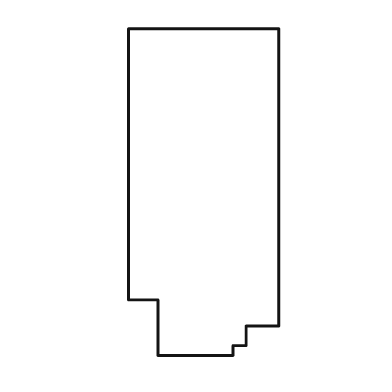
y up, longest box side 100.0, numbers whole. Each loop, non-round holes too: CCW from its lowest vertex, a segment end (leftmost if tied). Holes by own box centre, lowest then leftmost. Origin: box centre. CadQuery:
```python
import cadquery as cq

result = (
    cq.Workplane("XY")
    .moveTo(-14.0, -50.0)
    .lineTo(9.0, -50.0)
    .lineTo(9.0, -47.0)
    .lineTo(13.0, -47.0)
    .lineTo(13.0, -41.0)
    .lineTo(23.0, -41.0)
    .lineTo(23.0, 50.0)
    .lineTo(-23.0, 50.0)
    .lineTo(-23.0, -33.0)
    .lineTo(-14.0, -33.0)
    .close()
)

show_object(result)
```